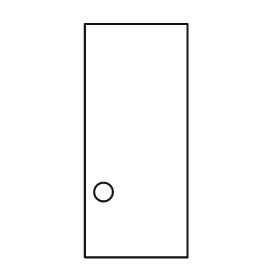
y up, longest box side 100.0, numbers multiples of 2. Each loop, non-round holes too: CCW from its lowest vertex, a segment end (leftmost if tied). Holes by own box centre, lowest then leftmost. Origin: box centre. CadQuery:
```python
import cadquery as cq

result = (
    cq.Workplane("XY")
    .moveTo(-22.0, -50.0)
    .lineTo(22.0, -50.0)
    .lineTo(22.0, 50.0)
    .lineTo(-22.0, 50.0)
    .close()
    .moveTo(-14.0, -22.0)
    .circle(4.0)
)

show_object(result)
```